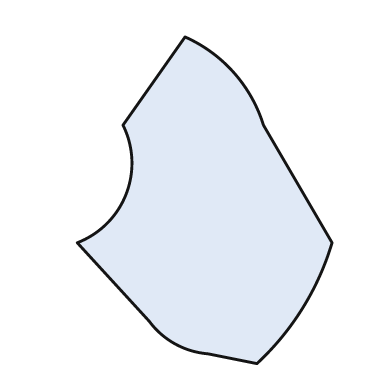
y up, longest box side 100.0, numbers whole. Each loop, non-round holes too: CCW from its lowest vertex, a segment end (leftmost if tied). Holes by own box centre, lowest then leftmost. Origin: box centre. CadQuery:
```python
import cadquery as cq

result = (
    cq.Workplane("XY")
    .moveTo(16.0, -50.0)
    .threePointArc((30.0, -33.0), (39.0, -13.0))
    .lineTo(18.0, 23.0)
    .threePointArc((9.0, 39.0), (-6.0, 50.0))
    .lineTo(-25.0, 23.0)
    .threePointArc((-24.0, 2.0), (-39.0, -13.0))
    .lineTo(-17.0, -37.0)
    .threePointArc((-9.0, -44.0), (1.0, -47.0))
    .close()
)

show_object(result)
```